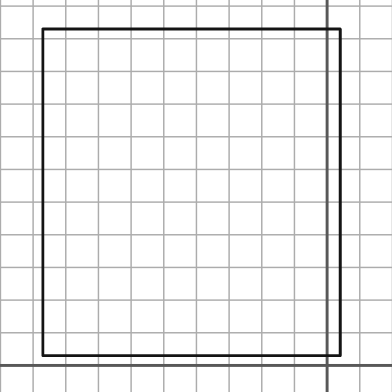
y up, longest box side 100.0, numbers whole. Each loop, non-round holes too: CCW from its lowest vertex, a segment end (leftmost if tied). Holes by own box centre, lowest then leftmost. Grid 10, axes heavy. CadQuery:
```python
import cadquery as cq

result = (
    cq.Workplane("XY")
    .moveTo(-87.0, 3.0)
    .lineTo(4.0, 3.0)
    .lineTo(4.0, 103.0)
    .lineTo(-87.0, 103.0)
    .close()
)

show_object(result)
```